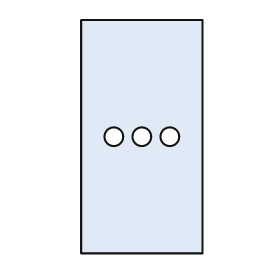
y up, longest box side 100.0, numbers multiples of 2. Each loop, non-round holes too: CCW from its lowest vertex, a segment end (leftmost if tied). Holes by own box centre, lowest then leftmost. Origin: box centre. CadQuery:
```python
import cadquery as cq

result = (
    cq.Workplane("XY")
    .moveTo(-26.0, -50.0)
    .lineTo(26.0, -50.0)
    .lineTo(26.0, 50.0)
    .lineTo(-26.0, 50.0)
    .close()
    .moveTo(-12.0, 0.0)
    .circle(4.0)
    .moveTo(0.0, 0.0)
    .circle(4.0)
    .moveTo(12.0, 0.0)
    .circle(4.0)
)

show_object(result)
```